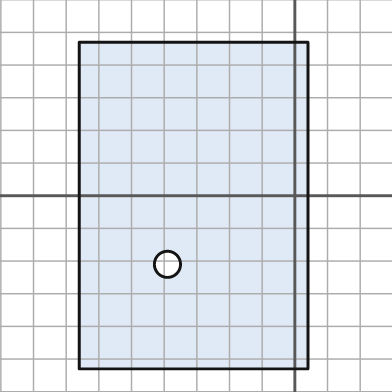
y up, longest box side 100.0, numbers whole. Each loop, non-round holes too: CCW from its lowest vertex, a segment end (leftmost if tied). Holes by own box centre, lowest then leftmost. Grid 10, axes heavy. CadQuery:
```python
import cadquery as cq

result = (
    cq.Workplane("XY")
    .moveTo(-66.0, -53.0)
    .lineTo(4.0, -53.0)
    .lineTo(4.0, 47.0)
    .lineTo(-66.0, 47.0)
    .close()
    .moveTo(-39.0, -21.0)
    .circle(4.0)
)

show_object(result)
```